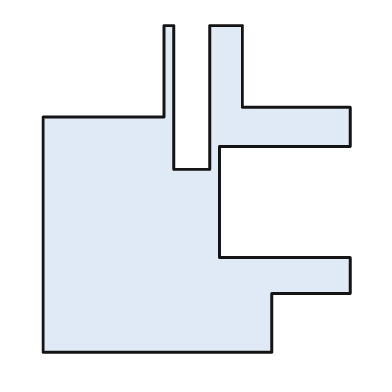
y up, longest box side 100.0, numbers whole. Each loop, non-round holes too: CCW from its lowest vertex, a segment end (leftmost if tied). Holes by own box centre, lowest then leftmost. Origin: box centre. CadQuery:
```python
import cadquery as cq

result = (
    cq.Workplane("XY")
    .moveTo(-47.0, -50.0)
    .lineTo(23.0, -50.0)
    .lineTo(23.0, -32.0)
    .lineTo(47.0, -32.0)
    .lineTo(47.0, -21.0)
    .lineTo(7.0, -21.0)
    .lineTo(7.0, 13.0)
    .lineTo(47.0, 13.0)
    .lineTo(47.0, 25.0)
    .lineTo(14.0, 25.0)
    .lineTo(14.0, 50.0)
    .lineTo(4.0, 50.0)
    .lineTo(4.0, 6.0)
    .lineTo(-7.0, 6.0)
    .lineTo(-7.0, 50.0)
    .lineTo(-10.0, 50.0)
    .lineTo(-10.0, 22.0)
    .lineTo(-47.0, 22.0)
    .close()
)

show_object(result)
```